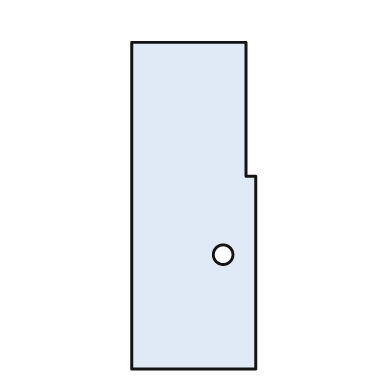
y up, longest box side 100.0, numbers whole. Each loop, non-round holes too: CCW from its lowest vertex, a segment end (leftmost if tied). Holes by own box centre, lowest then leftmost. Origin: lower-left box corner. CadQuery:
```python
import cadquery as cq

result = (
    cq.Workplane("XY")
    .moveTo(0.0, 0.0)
    .lineTo(38.0, 0.0)
    .lineTo(38.0, 59.0)
    .lineTo(35.0, 59.0)
    .lineTo(35.0, 100.0)
    .lineTo(0.0, 100.0)
    .close()
    .moveTo(28.0, 35.0)
    .circle(3.0)
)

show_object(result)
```